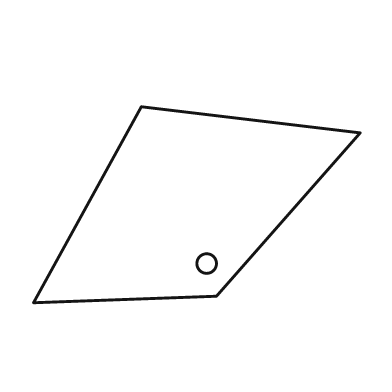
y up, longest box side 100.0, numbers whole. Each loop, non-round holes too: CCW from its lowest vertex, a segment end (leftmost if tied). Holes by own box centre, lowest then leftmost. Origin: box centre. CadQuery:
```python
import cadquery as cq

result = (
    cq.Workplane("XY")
    .moveTo(-50.0, -30.0)
    .lineTo(6.0, -28.0)
    .lineTo(50.0, 22.0)
    .lineTo(-17.0, 30.0)
    .close()
    .moveTo(3.0, -18.0)
    .circle(3.0)
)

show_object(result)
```